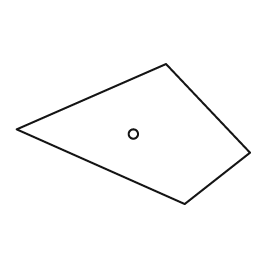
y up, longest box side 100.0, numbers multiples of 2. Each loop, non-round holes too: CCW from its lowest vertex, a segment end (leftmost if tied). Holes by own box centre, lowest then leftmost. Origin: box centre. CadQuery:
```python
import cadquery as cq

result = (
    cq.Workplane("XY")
    .moveTo(22.0, -30.0)
    .lineTo(50.0, -8.0)
    .lineTo(14.0, 30.0)
    .lineTo(-50.0, 2.0)
    .close()
    .moveTo(0.0, 0.0)
    .circle(2.0)
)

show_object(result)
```